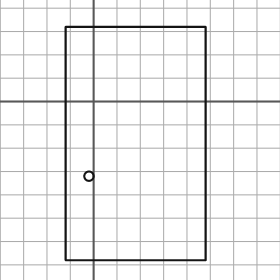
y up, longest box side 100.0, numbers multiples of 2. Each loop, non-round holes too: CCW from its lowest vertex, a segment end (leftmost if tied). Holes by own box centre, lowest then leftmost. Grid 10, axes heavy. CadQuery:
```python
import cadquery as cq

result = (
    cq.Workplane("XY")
    .moveTo(-12.0, -68.0)
    .lineTo(48.0, -68.0)
    .lineTo(48.0, 32.0)
    .lineTo(-12.0, 32.0)
    .close()
    .moveTo(-2.0, -32.0)
    .circle(2.0)
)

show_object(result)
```